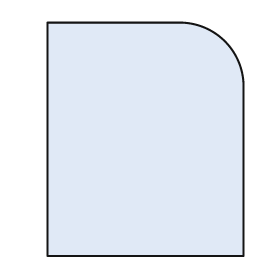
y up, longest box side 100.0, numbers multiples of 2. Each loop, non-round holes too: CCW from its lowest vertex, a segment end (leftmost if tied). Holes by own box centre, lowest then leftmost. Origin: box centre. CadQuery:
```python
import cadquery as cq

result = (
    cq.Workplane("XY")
    .moveTo(-42.0, -50.0)
    .lineTo(42.0, -50.0)
    .lineTo(42.0, 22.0)
    .threePointArc((34.0, 42.0), (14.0, 50.0))
    .lineTo(-42.0, 50.0)
    .close()
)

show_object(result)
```